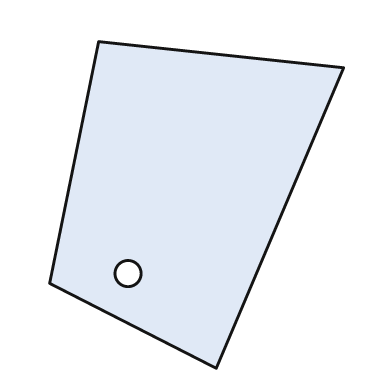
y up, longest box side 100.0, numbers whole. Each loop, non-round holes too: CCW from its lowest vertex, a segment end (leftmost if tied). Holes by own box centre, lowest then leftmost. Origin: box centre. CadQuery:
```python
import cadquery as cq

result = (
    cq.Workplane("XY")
    .moveTo(6.0, -50.0)
    .lineTo(45.0, 42.0)
    .lineTo(-30.0, 50.0)
    .lineTo(-45.0, -24.0)
    .close()
    .moveTo(-21.0, -21.0)
    .circle(4.0)
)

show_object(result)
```